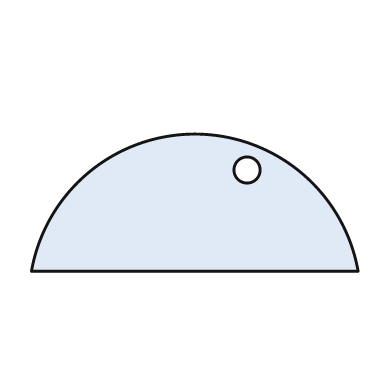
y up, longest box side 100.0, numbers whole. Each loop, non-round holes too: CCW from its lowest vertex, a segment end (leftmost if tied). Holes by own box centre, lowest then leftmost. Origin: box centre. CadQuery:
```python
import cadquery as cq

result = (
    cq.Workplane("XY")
    .moveTo(-50.0, -21.0)
    .lineTo(50.0, -21.0)
    .threePointArc((0.0, 21.0), (-50.0, -21.0))
    .close()
    .moveTo(16.0, 10.0)
    .circle(4.0)
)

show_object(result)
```